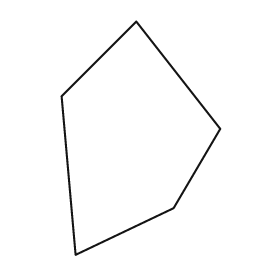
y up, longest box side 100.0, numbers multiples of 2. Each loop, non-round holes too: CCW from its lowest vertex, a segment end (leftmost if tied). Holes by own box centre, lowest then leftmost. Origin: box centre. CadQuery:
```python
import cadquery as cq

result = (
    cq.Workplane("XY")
    .moveTo(-28.0, -50.0)
    .lineTo(14.0, -30.0)
    .lineTo(34.0, 4.0)
    .lineTo(-2.0, 50.0)
    .lineTo(-34.0, 18.0)
    .close()
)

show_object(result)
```